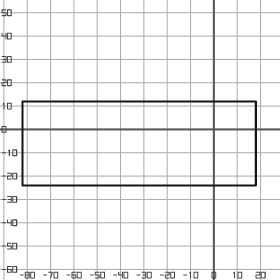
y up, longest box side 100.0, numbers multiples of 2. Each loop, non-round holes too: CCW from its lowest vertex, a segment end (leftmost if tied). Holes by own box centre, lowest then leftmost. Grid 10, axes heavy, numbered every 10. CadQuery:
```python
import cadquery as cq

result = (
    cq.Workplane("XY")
    .moveTo(-82.0, -24.0)
    .lineTo(18.0, -24.0)
    .lineTo(18.0, 12.0)
    .lineTo(-82.0, 12.0)
    .close()
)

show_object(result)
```